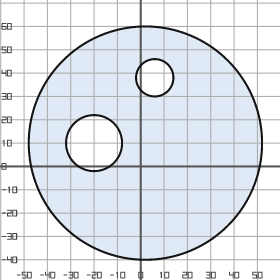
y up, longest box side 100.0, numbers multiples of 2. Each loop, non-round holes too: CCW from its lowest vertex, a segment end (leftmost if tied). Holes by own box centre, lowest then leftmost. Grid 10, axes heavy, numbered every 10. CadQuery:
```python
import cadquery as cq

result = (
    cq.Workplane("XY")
    .moveTo(2.0, 10.0)
    .circle(50.0)
    .moveTo(-20.0, 10.0)
    .circle(12.0)
    .moveTo(6.0, 38.0)
    .circle(8.0)
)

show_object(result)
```